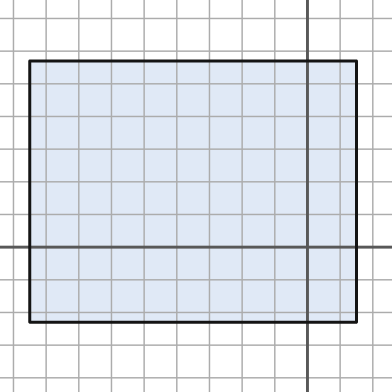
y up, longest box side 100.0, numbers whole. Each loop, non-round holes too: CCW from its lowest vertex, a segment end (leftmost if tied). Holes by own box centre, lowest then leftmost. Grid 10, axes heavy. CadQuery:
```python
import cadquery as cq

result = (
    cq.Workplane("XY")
    .moveTo(-85.0, -23.0)
    .lineTo(15.0, -23.0)
    .lineTo(15.0, 57.0)
    .lineTo(-85.0, 57.0)
    .close()
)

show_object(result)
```